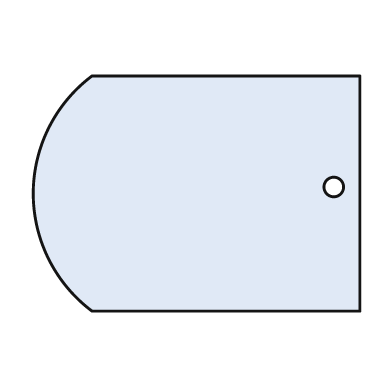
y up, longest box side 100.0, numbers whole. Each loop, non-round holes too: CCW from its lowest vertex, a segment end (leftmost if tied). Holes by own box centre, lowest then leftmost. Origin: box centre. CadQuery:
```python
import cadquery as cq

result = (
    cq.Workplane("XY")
    .moveTo(-32.0, -36.0)
    .lineTo(50.0, -36.0)
    .lineTo(50.0, 36.0)
    .lineTo(-32.0, 36.0)
    .threePointArc((-50.0, 0.0), (-32.0, -36.0))
    .close()
    .moveTo(42.0, 2.0)
    .circle(3.0)
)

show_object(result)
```